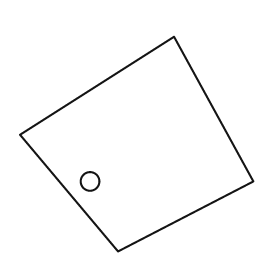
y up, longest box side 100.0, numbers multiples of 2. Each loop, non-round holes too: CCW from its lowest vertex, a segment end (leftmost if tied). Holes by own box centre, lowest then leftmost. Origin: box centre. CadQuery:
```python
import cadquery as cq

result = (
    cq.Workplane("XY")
    .moveTo(-8.0, -46.0)
    .lineTo(50.0, -16.0)
    .lineTo(16.0, 46.0)
    .lineTo(-50.0, 4.0)
    .close()
    .moveTo(-20.0, -16.0)
    .circle(4.0)
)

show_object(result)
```